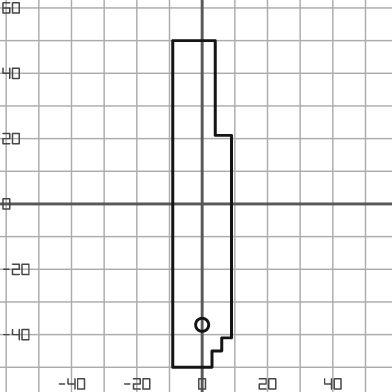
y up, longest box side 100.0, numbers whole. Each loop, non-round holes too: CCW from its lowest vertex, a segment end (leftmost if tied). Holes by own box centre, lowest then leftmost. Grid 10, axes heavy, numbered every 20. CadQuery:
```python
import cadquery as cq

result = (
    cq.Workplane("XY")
    .moveTo(-9.0, -50.0)
    .lineTo(3.0, -50.0)
    .lineTo(3.0, -45.0)
    .lineTo(6.0, -45.0)
    .lineTo(6.0, -41.0)
    .lineTo(9.0, -41.0)
    .lineTo(9.0, 21.0)
    .lineTo(4.0, 21.0)
    .lineTo(4.0, 50.0)
    .lineTo(-9.0, 50.0)
    .close()
    .moveTo(0.0, -37.0)
    .circle(2.0)
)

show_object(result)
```